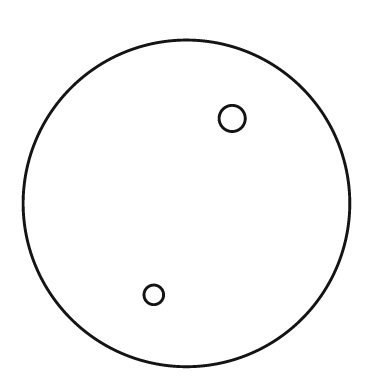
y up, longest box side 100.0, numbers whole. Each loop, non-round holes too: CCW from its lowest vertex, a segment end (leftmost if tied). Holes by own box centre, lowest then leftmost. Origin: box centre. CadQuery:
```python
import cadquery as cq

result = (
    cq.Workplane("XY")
    .moveTo(0.0, 0.0)
    .circle(50.0)
    .moveTo(-10.0, -28.0)
    .circle(3.0)
    .moveTo(14.0, 26.0)
    .circle(4.0)
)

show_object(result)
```